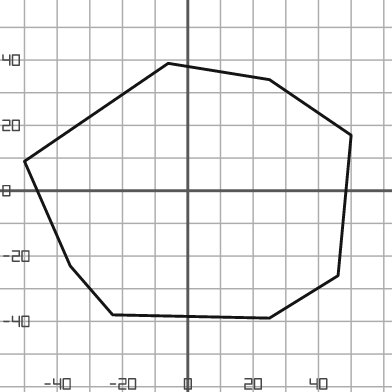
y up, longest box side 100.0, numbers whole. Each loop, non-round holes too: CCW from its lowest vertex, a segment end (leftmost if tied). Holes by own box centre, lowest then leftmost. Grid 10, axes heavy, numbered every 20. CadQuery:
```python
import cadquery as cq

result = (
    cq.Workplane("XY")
    .moveTo(25.0, -39.0)
    .lineTo(46.0, -26.0)
    .lineTo(50.0, 17.0)
    .lineTo(25.0, 34.0)
    .lineTo(-6.0, 39.0)
    .lineTo(-50.0, 9.0)
    .lineTo(-36.0, -23.0)
    .lineTo(-23.0, -38.0)
    .close()
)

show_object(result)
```